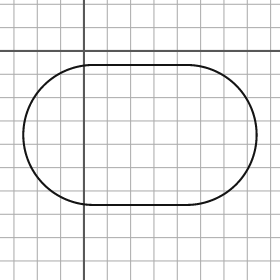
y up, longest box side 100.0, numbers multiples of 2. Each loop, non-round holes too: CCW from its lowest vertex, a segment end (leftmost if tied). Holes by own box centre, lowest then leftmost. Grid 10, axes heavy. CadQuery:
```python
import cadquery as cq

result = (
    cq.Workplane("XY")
    .moveTo(4.0, -66.0)
    .lineTo(44.0, -66.0)
    .threePointArc((74.0, -36.0), (44.0, -6.0))
    .lineTo(4.0, -6.0)
    .threePointArc((-26.0, -36.0), (4.0, -66.0))
    .close()
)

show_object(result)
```